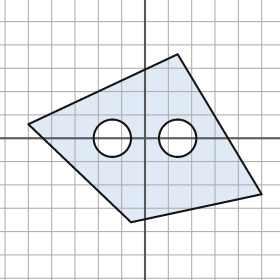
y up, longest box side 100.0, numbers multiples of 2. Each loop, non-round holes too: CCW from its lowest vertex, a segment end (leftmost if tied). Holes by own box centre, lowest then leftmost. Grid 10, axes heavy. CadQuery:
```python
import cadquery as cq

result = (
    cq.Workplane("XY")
    .moveTo(-6.0, -36.0)
    .lineTo(50.0, -24.0)
    .lineTo(14.0, 36.0)
    .lineTo(-50.0, 6.0)
    .close()
    .moveTo(-14.0, 0.0)
    .circle(8.0)
    .moveTo(14.0, 0.0)
    .circle(8.0)
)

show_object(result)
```